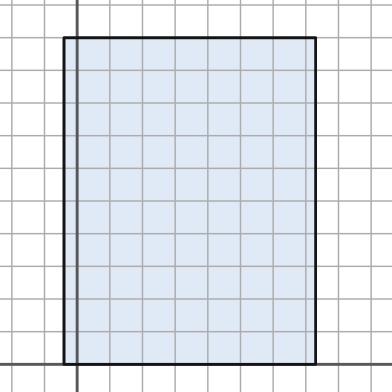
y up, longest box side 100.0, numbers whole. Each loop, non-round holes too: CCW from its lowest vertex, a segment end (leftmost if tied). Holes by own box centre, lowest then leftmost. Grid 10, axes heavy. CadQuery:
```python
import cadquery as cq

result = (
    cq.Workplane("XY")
    .moveTo(-4.0, 0.0)
    .lineTo(73.0, 0.0)
    .lineTo(73.0, 100.0)
    .lineTo(-4.0, 100.0)
    .close()
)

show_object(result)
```